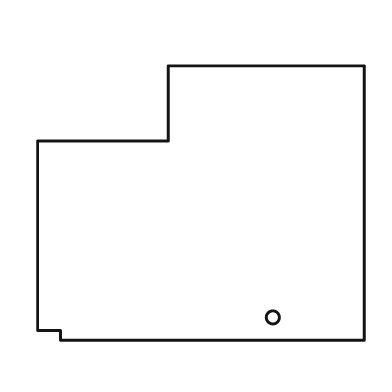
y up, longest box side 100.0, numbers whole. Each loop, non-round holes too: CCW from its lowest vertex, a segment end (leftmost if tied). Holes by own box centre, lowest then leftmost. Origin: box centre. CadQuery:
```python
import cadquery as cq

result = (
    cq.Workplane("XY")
    .moveTo(-43.0, -42.0)
    .lineTo(50.0, -42.0)
    .lineTo(50.0, 42.0)
    .lineTo(-10.0, 42.0)
    .lineTo(-10.0, 19.0)
    .lineTo(-50.0, 19.0)
    .lineTo(-50.0, -39.0)
    .lineTo(-43.0, -39.0)
    .close()
    .moveTo(22.0, -35.0)
    .circle(2.0)
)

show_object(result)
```